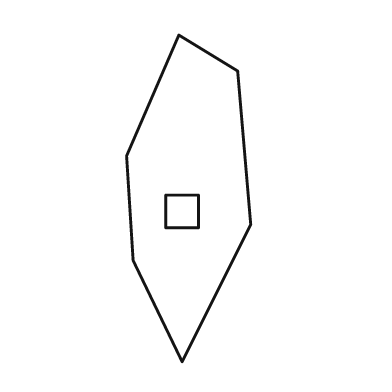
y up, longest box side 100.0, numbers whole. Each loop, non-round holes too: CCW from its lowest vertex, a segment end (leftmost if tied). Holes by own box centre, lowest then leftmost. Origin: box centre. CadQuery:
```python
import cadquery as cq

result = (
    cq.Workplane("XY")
    .moveTo(-2.0, -50.0)
    .lineTo(19.0, -8.0)
    .lineTo(15.0, 39.0)
    .lineTo(-3.0, 50.0)
    .lineTo(-19.0, 13.0)
    .lineTo(-17.0, -19.0)
    .close()
    .moveTo(-7.0, -9.0)
    .lineTo(3.0, -9.0)
    .lineTo(3.0, 1.0)
    .lineTo(-7.0, 1.0)
    .close()
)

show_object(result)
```